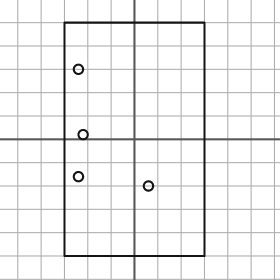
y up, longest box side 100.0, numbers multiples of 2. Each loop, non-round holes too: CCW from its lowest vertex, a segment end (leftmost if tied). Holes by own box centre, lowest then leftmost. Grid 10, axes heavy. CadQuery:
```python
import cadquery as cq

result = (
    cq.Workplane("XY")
    .moveTo(-30.0, -50.0)
    .lineTo(30.0, -50.0)
    .lineTo(30.0, 50.0)
    .lineTo(-30.0, 50.0)
    .close()
    .moveTo(6.0, -20.0)
    .circle(2.0)
    .moveTo(-24.0, -16.0)
    .circle(2.0)
    .moveTo(-22.0, 2.0)
    .circle(2.0)
    .moveTo(-24.0, 30.0)
    .circle(2.0)
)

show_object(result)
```